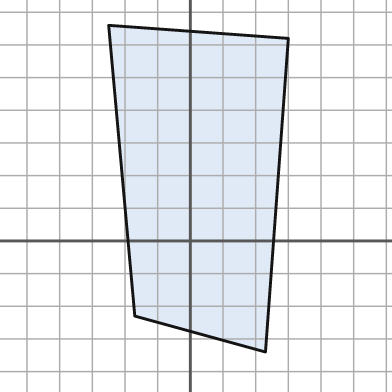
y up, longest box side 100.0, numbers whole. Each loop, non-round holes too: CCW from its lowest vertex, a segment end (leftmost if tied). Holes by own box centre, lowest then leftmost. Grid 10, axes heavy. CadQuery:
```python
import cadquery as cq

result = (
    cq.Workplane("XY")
    .moveTo(23.0, -34.0)
    .lineTo(30.0, 62.0)
    .lineTo(-25.0, 66.0)
    .lineTo(-17.0, -23.0)
    .close()
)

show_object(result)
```